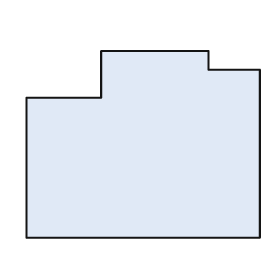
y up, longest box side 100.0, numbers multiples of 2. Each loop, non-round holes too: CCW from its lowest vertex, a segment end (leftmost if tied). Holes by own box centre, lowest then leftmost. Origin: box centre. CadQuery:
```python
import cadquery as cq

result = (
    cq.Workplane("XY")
    .moveTo(-50.0, -40.0)
    .lineTo(50.0, -40.0)
    .lineTo(50.0, 32.0)
    .lineTo(28.0, 32.0)
    .lineTo(28.0, 40.0)
    .lineTo(-18.0, 40.0)
    .lineTo(-18.0, 20.0)
    .lineTo(-50.0, 20.0)
    .close()
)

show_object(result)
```